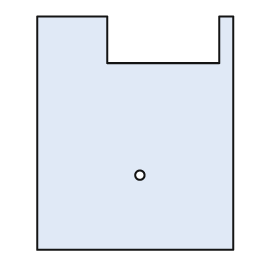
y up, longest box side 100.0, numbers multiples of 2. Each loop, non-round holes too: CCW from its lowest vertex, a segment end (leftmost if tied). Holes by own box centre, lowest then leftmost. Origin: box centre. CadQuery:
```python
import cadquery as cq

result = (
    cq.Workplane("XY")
    .moveTo(-42.0, -50.0)
    .lineTo(42.0, -50.0)
    .lineTo(42.0, 50.0)
    .lineTo(36.0, 50.0)
    .lineTo(36.0, 30.0)
    .lineTo(-12.0, 30.0)
    .lineTo(-12.0, 50.0)
    .lineTo(-42.0, 50.0)
    .close()
    .moveTo(2.0, -18.0)
    .circle(2.0)
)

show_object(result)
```